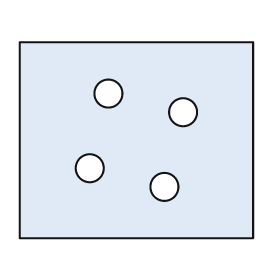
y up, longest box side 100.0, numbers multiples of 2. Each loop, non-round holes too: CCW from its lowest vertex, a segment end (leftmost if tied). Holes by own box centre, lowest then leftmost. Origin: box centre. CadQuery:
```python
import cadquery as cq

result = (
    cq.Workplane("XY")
    .moveTo(-50.0, -42.0)
    .lineTo(50.0, -42.0)
    .lineTo(50.0, 42.0)
    .lineTo(-50.0, 42.0)
    .close()
    .moveTo(12.0, -20.0)
    .circle(6.0)
    .moveTo(-20.0, -12.0)
    .circle(6.0)
    .moveTo(20.0, 12.0)
    .circle(6.0)
    .moveTo(-12.0, 20.0)
    .circle(6.0)
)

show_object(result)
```